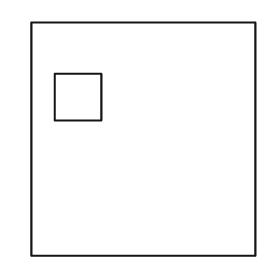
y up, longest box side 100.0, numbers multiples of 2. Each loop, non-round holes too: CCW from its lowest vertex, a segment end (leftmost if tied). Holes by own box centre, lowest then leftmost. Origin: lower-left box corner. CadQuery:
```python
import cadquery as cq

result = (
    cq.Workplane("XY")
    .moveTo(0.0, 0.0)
    .lineTo(96.0, 0.0)
    .lineTo(96.0, 100.0)
    .lineTo(0.0, 100.0)
    .close()
    .moveTo(10.0, 58.0)
    .lineTo(30.0, 58.0)
    .lineTo(30.0, 78.0)
    .lineTo(10.0, 78.0)
    .close()
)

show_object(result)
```